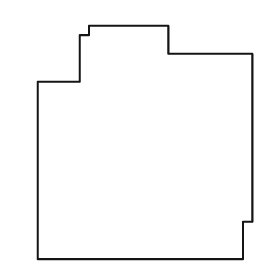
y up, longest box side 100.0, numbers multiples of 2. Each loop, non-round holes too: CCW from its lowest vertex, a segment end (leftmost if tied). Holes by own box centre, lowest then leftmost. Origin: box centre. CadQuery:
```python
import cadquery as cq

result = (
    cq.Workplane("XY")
    .moveTo(-46.0, -50.0)
    .lineTo(42.0, -50.0)
    .lineTo(42.0, -34.0)
    .lineTo(46.0, -34.0)
    .lineTo(46.0, 38.0)
    .lineTo(10.0, 38.0)
    .lineTo(10.0, 50.0)
    .lineTo(-24.0, 50.0)
    .lineTo(-24.0, 46.0)
    .lineTo(-28.0, 46.0)
    .lineTo(-28.0, 26.0)
    .lineTo(-46.0, 26.0)
    .close()
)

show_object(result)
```